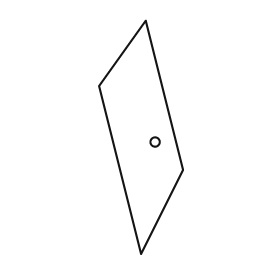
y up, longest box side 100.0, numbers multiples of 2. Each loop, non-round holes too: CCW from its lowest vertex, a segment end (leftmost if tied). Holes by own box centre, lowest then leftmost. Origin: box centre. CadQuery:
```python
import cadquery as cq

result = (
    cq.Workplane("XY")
    .moveTo(0.0, -50.0)
    .lineTo(18.0, -14.0)
    .lineTo(2.0, 50.0)
    .lineTo(-18.0, 22.0)
    .close()
    .moveTo(6.0, -2.0)
    .circle(2.0)
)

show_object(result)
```